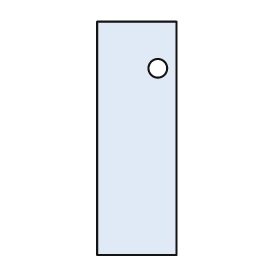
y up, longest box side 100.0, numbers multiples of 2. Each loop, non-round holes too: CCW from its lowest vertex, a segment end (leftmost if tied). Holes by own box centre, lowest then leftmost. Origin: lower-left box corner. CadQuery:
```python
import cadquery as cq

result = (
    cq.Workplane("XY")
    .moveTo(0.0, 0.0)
    .lineTo(34.0, 0.0)
    .lineTo(34.0, 100.0)
    .lineTo(0.0, 100.0)
    .close()
    .moveTo(26.0, 80.0)
    .circle(4.0)
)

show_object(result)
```